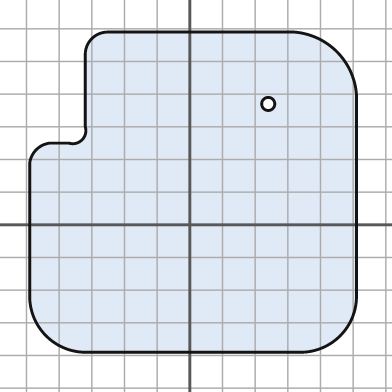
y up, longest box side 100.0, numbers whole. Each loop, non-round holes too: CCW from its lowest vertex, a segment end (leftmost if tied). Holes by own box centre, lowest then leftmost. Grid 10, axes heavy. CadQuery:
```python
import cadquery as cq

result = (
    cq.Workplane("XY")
    .moveTo(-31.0, -39.0)
    .lineTo(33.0, -39.0)
    .threePointArc((46.0, -34.0), (51.0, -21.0))
    .lineTo(51.0, 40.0)
    .threePointArc((45.0, 53.0), (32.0, 59.0))
    .lineTo(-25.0, 59.0)
    .threePointArc((-30.0, 57.0), (-32.0, 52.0))
    .lineTo(-32.0, 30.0)
    .threePointArc((-33.0, 26.0), (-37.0, 25.0))
    .lineTo(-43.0, 25.0)
    .threePointArc((-47.0, 23.0), (-49.0, 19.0))
    .lineTo(-49.0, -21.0)
    .threePointArc((-44.0, -34.0), (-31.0, -39.0))
    .close()
    .moveTo(24.0, 37.0)
    .circle(2.0)
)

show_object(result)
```